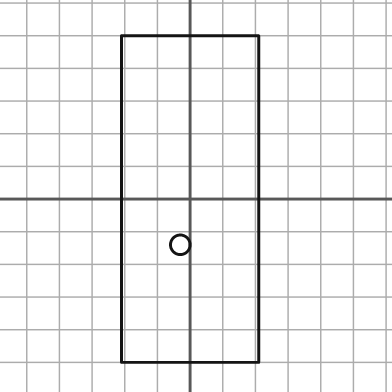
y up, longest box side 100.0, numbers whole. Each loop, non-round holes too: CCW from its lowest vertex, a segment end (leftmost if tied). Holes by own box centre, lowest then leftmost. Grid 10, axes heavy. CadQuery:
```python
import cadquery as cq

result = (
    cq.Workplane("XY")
    .moveTo(-21.0, -50.0)
    .lineTo(21.0, -50.0)
    .lineTo(21.0, 50.0)
    .lineTo(-21.0, 50.0)
    .close()
    .moveTo(-3.0, -14.0)
    .circle(3.0)
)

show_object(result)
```